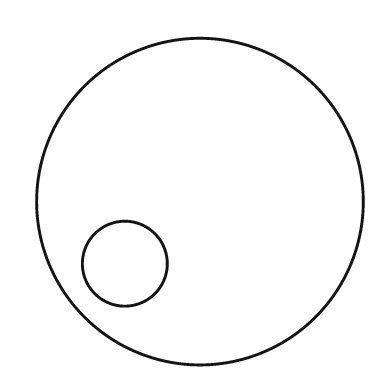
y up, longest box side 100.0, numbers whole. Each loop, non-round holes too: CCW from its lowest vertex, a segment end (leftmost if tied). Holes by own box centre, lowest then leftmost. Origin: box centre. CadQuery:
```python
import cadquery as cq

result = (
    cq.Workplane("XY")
    .moveTo(0.0, 0.0)
    .circle(50.0)
    .moveTo(-23.0, -19.0)
    .circle(13.0)
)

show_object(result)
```